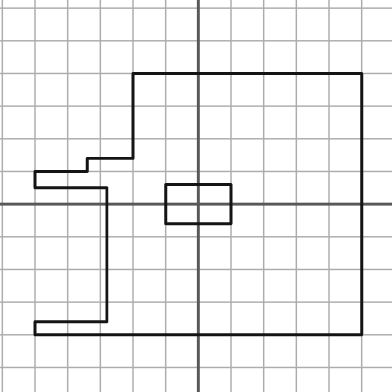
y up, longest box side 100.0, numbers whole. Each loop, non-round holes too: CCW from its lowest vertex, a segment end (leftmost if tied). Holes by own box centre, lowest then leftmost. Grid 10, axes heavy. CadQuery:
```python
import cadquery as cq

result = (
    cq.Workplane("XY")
    .moveTo(-50.0, -40.0)
    .lineTo(50.0, -40.0)
    .lineTo(50.0, 40.0)
    .lineTo(-20.0, 40.0)
    .lineTo(-20.0, 14.0)
    .lineTo(-34.0, 14.0)
    .lineTo(-34.0, 10.0)
    .lineTo(-50.0, 10.0)
    .lineTo(-50.0, 5.0)
    .lineTo(-28.0, 5.0)
    .lineTo(-28.0, -36.0)
    .lineTo(-50.0, -36.0)
    .close()
    .moveTo(-10.0, -6.0)
    .lineTo(10.0, -6.0)
    .lineTo(10.0, 6.0)
    .lineTo(-10.0, 6.0)
    .close()
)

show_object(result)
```